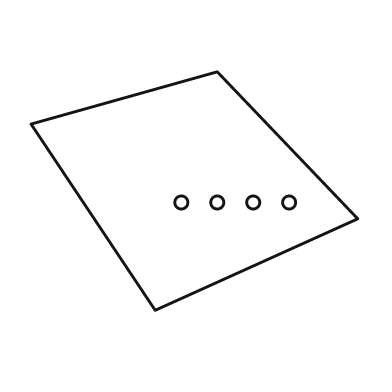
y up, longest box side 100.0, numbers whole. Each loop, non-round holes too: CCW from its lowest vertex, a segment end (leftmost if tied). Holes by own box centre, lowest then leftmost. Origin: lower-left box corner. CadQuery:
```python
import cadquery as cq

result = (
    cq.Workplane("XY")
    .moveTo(38.0, 0.0)
    .lineTo(100.0, 28.0)
    .lineTo(57.0, 73.0)
    .lineTo(0.0, 57.0)
    .close()
    .moveTo(46.0, 33.0)
    .circle(2.0)
    .moveTo(57.0, 33.0)
    .circle(2.0)
    .moveTo(68.0, 33.0)
    .circle(2.0)
    .moveTo(79.0, 33.0)
    .circle(2.0)
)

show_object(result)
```